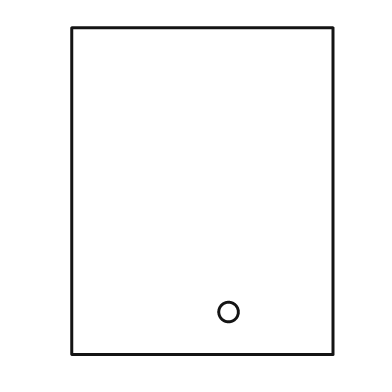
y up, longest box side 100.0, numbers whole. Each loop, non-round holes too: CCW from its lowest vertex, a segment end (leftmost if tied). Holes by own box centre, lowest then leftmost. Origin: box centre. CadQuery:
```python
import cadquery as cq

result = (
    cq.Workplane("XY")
    .moveTo(-40.0, -50.0)
    .lineTo(40.0, -50.0)
    .lineTo(40.0, 50.0)
    .lineTo(-40.0, 50.0)
    .close()
    .moveTo(8.0, -37.0)
    .circle(3.0)
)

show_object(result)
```